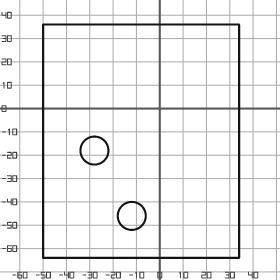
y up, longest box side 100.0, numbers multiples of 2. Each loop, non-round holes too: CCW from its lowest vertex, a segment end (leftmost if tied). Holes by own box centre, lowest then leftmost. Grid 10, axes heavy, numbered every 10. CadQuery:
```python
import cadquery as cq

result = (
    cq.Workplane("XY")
    .moveTo(-50.0, -64.0)
    .lineTo(34.0, -64.0)
    .lineTo(34.0, 36.0)
    .lineTo(-50.0, 36.0)
    .close()
    .moveTo(-12.0, -46.0)
    .circle(6.0)
    .moveTo(-28.0, -18.0)
    .circle(6.0)
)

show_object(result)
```